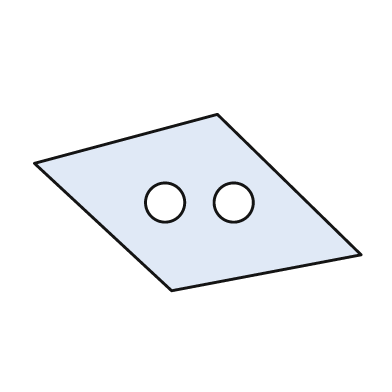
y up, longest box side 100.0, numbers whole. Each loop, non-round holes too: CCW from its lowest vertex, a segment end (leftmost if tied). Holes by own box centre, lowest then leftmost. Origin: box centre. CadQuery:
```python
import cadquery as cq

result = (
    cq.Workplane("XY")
    .moveTo(-8.0, -27.0)
    .lineTo(50.0, -16.0)
    .lineTo(6.0, 27.0)
    .lineTo(-50.0, 12.0)
    .close()
    .moveTo(-10.0, 0.0)
    .circle(6.0)
    .moveTo(11.0, 0.0)
    .circle(6.0)
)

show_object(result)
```